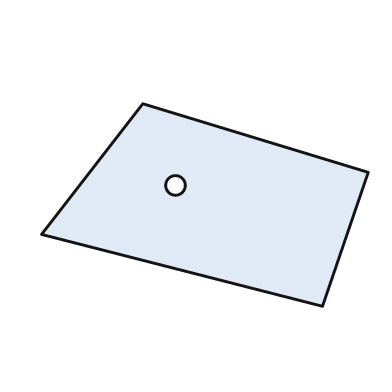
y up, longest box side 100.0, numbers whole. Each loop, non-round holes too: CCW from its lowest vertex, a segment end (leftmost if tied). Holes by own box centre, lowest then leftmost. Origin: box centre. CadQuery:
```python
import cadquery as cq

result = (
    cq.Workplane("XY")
    .moveTo(36.0, -31.0)
    .lineTo(50.0, 10.0)
    .lineTo(-19.0, 31.0)
    .lineTo(-50.0, -9.0)
    .close()
    .moveTo(-9.0, 6.0)
    .circle(3.0)
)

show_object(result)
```